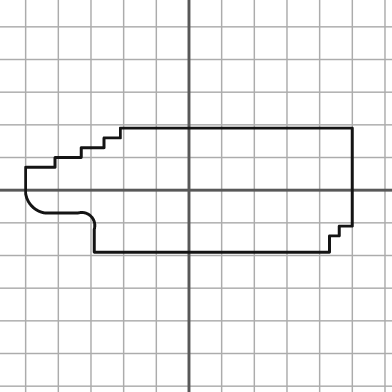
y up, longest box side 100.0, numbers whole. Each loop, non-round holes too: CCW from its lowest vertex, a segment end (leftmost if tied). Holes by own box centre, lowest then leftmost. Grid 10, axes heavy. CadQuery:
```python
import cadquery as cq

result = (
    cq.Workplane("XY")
    .moveTo(-29.0, -19.0)
    .lineTo(43.0, -19.0)
    .lineTo(43.0, -14.0)
    .lineTo(46.0, -14.0)
    .lineTo(46.0, -11.0)
    .lineTo(50.0, -11.0)
    .lineTo(50.0, 19.0)
    .lineTo(-21.0, 19.0)
    .lineTo(-21.0, 16.0)
    .lineTo(-26.0, 16.0)
    .lineTo(-26.0, 13.0)
    .lineTo(-33.0, 13.0)
    .lineTo(-33.0, 10.0)
    .lineTo(-41.0, 10.0)
    .lineTo(-41.0, 7.0)
    .lineTo(-50.0, 7.0)
    .lineTo(-50.0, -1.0)
    .threePointArc((-48.0, -5.0), (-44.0, -7.0))
    .lineTo(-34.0, -7.0)
    .threePointArc((-30.0, -8.0), (-29.0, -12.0))
    .close()
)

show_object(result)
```